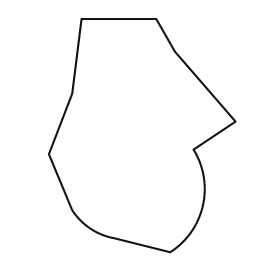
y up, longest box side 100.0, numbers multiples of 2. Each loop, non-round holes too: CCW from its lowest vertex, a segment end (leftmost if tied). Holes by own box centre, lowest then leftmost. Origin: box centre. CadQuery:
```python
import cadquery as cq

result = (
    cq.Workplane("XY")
    .moveTo(12.0, -50.0)
    .threePointArc((26.0, -30.0), (22.0, -6.0))
    .lineTo(40.0, 6.0)
    .lineTo(14.0, 36.0)
    .lineTo(6.0, 50.0)
    .lineTo(-26.0, 50.0)
    .lineTo(-30.0, 18.0)
    .lineTo(-40.0, -8.0)
    .lineTo(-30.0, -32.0)
    .threePointArc((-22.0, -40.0), (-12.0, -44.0))
    .close()
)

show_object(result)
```